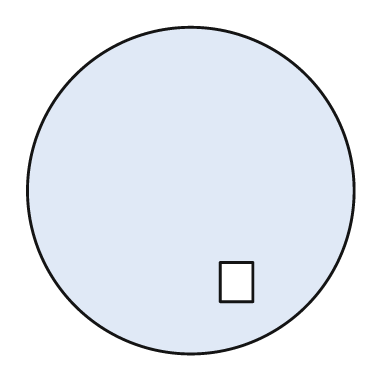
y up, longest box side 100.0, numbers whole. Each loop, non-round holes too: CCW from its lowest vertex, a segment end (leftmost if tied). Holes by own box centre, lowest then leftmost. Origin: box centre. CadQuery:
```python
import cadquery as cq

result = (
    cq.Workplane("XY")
    .moveTo(0.0, 0.0)
    .circle(50.0)
    .moveTo(9.0, -34.0)
    .lineTo(19.0, -34.0)
    .lineTo(19.0, -22.0)
    .lineTo(9.0, -22.0)
    .close()
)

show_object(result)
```